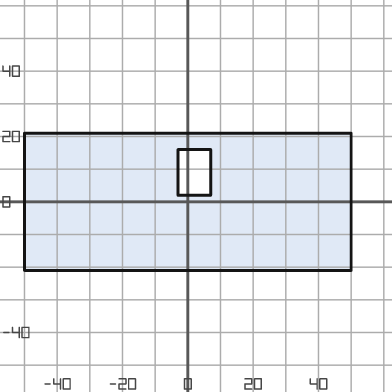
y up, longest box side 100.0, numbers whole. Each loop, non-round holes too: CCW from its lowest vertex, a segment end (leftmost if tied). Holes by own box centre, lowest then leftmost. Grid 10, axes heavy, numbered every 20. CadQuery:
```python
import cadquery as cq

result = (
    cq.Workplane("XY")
    .moveTo(-50.0, -21.0)
    .lineTo(50.0, -21.0)
    .lineTo(50.0, 21.0)
    .lineTo(-50.0, 21.0)
    .close()
    .moveTo(-3.0, 2.0)
    .lineTo(7.0, 2.0)
    .lineTo(7.0, 16.0)
    .lineTo(-3.0, 16.0)
    .close()
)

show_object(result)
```